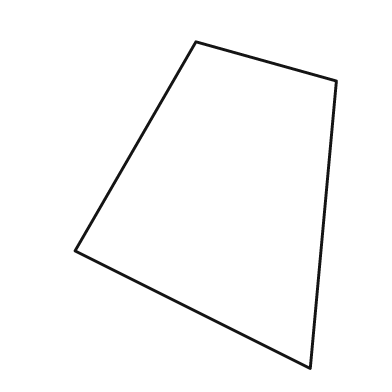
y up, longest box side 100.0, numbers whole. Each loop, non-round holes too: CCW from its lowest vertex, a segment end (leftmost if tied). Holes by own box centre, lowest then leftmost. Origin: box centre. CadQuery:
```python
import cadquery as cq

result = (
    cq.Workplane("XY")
    .moveTo(32.0, -50.0)
    .lineTo(40.0, 38.0)
    .lineTo(-3.0, 50.0)
    .lineTo(-40.0, -14.0)
    .close()
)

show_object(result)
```